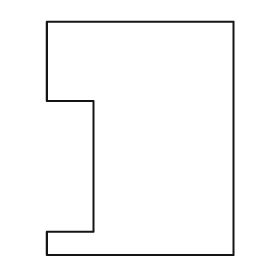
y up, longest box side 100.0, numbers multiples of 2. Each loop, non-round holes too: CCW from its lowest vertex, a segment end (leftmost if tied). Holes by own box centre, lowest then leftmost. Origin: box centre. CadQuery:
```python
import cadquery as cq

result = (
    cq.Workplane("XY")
    .moveTo(-40.0, -50.0)
    .lineTo(40.0, -50.0)
    .lineTo(40.0, 50.0)
    .lineTo(-40.0, 50.0)
    .lineTo(-40.0, 16.0)
    .lineTo(-20.0, 16.0)
    .lineTo(-20.0, -40.0)
    .lineTo(-40.0, -40.0)
    .close()
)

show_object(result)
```